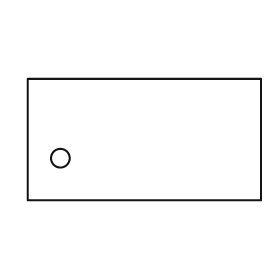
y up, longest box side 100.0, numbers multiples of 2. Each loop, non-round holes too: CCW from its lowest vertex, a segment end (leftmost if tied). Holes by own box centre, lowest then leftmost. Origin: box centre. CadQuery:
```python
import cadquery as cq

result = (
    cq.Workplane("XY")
    .moveTo(-50.0, -26.0)
    .lineTo(50.0, -26.0)
    .lineTo(50.0, 26.0)
    .lineTo(-50.0, 26.0)
    .close()
    .moveTo(-36.0, -8.0)
    .circle(4.0)
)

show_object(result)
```